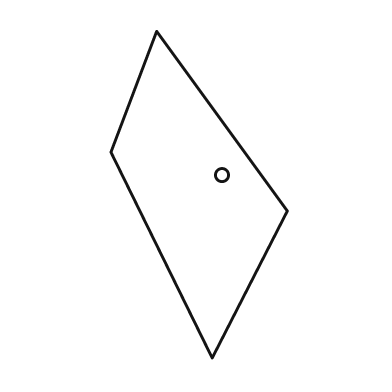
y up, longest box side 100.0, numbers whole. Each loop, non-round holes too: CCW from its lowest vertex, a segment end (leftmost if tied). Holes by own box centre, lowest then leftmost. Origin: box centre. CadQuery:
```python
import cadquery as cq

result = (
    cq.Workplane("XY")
    .moveTo(4.0, -50.0)
    .lineTo(27.0, -5.0)
    .lineTo(-13.0, 50.0)
    .lineTo(-27.0, 13.0)
    .close()
    .moveTo(7.0, 6.0)
    .circle(2.0)
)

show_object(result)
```